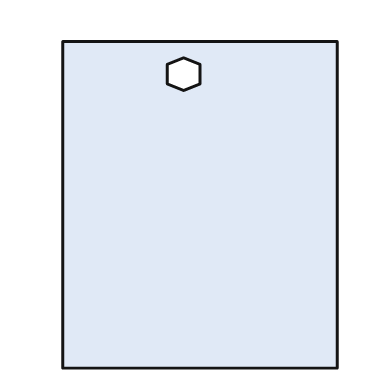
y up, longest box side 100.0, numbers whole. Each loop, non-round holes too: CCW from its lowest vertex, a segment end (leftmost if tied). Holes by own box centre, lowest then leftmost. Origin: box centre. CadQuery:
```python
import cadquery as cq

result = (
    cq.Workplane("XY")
    .moveTo(-42.0, -50.0)
    .lineTo(42.0, -50.0)
    .lineTo(42.0, 50.0)
    .lineTo(-42.0, 50.0)
    .close()
    .moveTo(-5.0, 35.0)
    .lineTo(0.0, 37.0)
    .lineTo(0.0, 43.0)
    .lineTo(-5.0, 45.0)
    .lineTo(-10.0, 43.0)
    .lineTo(-10.0, 37.0)
    .close()
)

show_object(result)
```